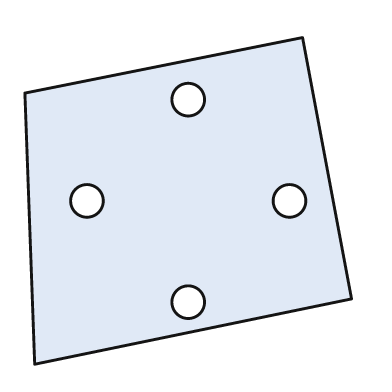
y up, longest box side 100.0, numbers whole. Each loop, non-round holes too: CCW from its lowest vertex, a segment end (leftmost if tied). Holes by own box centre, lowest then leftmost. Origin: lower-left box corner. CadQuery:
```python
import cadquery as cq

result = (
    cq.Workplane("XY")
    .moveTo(3.0, 0.0)
    .lineTo(100.0, 20.0)
    .lineTo(85.0, 100.0)
    .lineTo(0.0, 83.0)
    .close()
    .moveTo(50.0, 19.0)
    .circle(5.0)
    .moveTo(19.0, 50.0)
    .circle(5.0)
    .moveTo(81.0, 50.0)
    .circle(5.0)
    .moveTo(50.0, 81.0)
    .circle(5.0)
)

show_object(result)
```